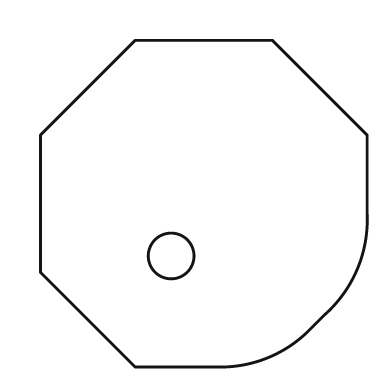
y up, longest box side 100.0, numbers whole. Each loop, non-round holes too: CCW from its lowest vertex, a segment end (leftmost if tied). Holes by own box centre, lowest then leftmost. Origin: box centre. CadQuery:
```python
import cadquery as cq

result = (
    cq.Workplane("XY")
    .moveTo(-21.0, -50.0)
    .lineTo(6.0, -50.0)
    .threePointArc((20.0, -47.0), (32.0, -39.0))
    .lineTo(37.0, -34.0)
    .threePointArc((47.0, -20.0), (50.0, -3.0))
    .lineTo(50.0, 21.0)
    .lineTo(21.0, 50.0)
    .lineTo(-21.0, 50.0)
    .lineTo(-50.0, 21.0)
    .lineTo(-50.0, -21.0)
    .close()
    .moveTo(-10.0, -16.0)
    .circle(7.0)
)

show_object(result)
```